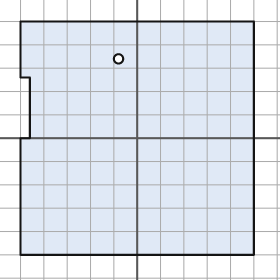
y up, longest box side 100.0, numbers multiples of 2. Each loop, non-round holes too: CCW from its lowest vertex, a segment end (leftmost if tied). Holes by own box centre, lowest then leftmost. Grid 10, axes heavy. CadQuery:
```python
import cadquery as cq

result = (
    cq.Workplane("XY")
    .moveTo(-50.0, -50.0)
    .lineTo(50.0, -50.0)
    .lineTo(50.0, 50.0)
    .lineTo(-50.0, 50.0)
    .lineTo(-50.0, 26.0)
    .lineTo(-46.0, 26.0)
    .lineTo(-46.0, 0.0)
    .lineTo(-50.0, 0.0)
    .close()
    .moveTo(-8.0, 34.0)
    .circle(2.0)
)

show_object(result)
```